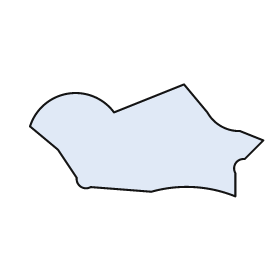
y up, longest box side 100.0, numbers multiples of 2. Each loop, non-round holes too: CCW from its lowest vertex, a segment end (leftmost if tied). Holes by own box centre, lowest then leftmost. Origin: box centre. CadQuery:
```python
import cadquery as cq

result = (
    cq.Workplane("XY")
    .moveTo(38.0, -24.0)
    .lineTo(38.0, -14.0)
    .threePointArc((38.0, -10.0), (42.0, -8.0))
    .lineTo(50.0, 0.0)
    .lineTo(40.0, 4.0)
    .threePointArc((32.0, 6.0), (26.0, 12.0))
    .lineTo(16.0, 24.0)
    .lineTo(-14.0, 12.0)
    .threePointArc((-34.0, 20.0), (-50.0, 6.0))
    .lineTo(-38.0, -4.0)
    .lineTo(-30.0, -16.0)
    .threePointArc((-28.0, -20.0), (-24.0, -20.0))
    .lineTo(2.0, -22.0)
    .threePointArc((20.0, -20.0), (38.0, -24.0))
    .close()
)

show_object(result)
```